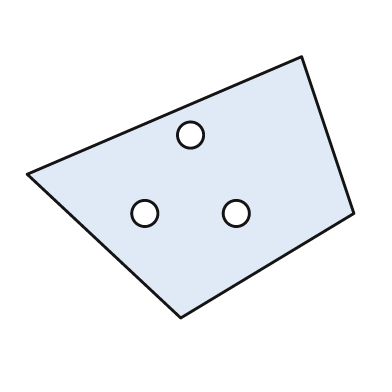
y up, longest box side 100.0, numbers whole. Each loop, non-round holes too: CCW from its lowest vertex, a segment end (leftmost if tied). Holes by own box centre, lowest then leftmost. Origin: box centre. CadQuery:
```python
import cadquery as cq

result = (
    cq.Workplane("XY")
    .moveTo(-3.0, -40.0)
    .lineTo(50.0, -8.0)
    .lineTo(34.0, 40.0)
    .lineTo(-50.0, 4.0)
    .close()
    .moveTo(-14.0, -8.0)
    .circle(4.0)
    .moveTo(14.0, -8.0)
    .circle(4.0)
    .moveTo(0.0, 16.0)
    .circle(4.0)
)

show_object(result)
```